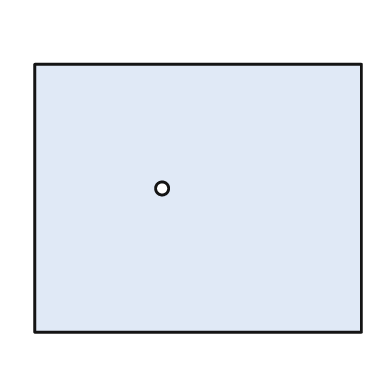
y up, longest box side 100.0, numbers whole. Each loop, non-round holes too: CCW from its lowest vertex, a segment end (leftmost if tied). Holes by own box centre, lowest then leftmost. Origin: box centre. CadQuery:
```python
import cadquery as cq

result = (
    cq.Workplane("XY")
    .moveTo(-50.0, -41.0)
    .lineTo(50.0, -41.0)
    .lineTo(50.0, 41.0)
    .lineTo(-50.0, 41.0)
    .close()
    .moveTo(-11.0, 3.0)
    .circle(2.0)
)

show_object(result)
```